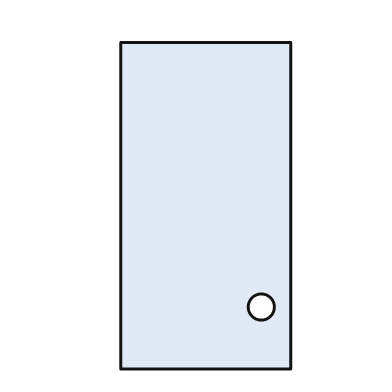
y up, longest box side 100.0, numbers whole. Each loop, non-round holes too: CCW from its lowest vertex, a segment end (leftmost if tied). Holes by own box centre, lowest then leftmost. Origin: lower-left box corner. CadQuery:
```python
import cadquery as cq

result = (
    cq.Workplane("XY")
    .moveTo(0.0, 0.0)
    .lineTo(52.0, 0.0)
    .lineTo(52.0, 100.0)
    .lineTo(0.0, 100.0)
    .close()
    .moveTo(43.0, 19.0)
    .circle(4.0)
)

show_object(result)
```